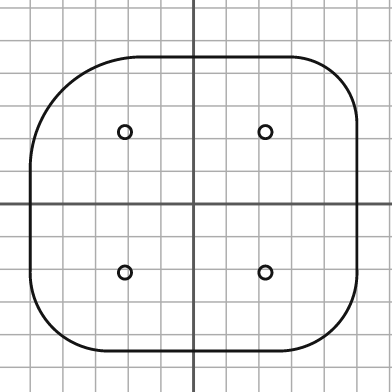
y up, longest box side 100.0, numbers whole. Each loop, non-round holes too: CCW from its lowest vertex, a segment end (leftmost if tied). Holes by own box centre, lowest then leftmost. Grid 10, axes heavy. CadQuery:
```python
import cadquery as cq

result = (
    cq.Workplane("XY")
    .moveTo(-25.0, -45.0)
    .lineTo(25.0, -45.0)
    .threePointArc((43.0, -38.0), (50.0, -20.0))
    .lineTo(50.0, 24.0)
    .threePointArc((44.0, 39.0), (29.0, 45.0))
    .lineTo(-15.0, 45.0)
    .threePointArc((-40.0, 35.0), (-50.0, 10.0))
    .lineTo(-50.0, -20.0)
    .threePointArc((-43.0, -38.0), (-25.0, -45.0))
    .close()
    .moveTo(-21.0, -21.0)
    .circle(2.0)
    .moveTo(22.0, -21.0)
    .circle(2.0)
    .moveTo(-21.0, 22.0)
    .circle(2.0)
    .moveTo(22.0, 22.0)
    .circle(2.0)
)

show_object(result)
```